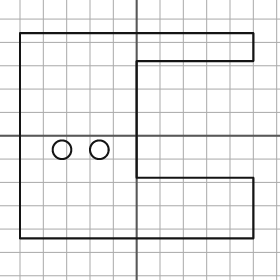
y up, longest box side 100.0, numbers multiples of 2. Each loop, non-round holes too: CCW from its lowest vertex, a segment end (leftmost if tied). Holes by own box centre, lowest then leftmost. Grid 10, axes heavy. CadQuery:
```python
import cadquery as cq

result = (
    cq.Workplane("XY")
    .moveTo(-50.0, -44.0)
    .lineTo(50.0, -44.0)
    .lineTo(50.0, -18.0)
    .lineTo(0.0, -18.0)
    .lineTo(0.0, 32.0)
    .lineTo(50.0, 32.0)
    .lineTo(50.0, 44.0)
    .lineTo(-50.0, 44.0)
    .close()
    .moveTo(-32.0, -6.0)
    .circle(4.0)
    .moveTo(-16.0, -6.0)
    .circle(4.0)
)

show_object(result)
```